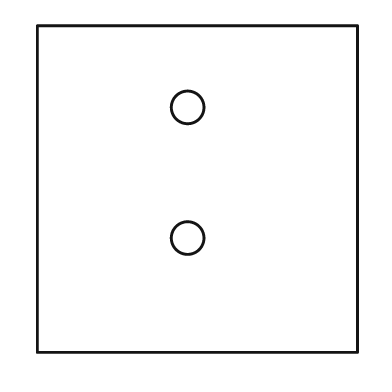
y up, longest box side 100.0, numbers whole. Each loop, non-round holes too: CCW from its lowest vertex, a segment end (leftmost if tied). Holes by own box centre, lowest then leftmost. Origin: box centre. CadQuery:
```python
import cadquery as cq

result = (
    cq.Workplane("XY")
    .moveTo(-49.0, -50.0)
    .lineTo(49.0, -50.0)
    .lineTo(49.0, 50.0)
    .lineTo(-49.0, 50.0)
    .close()
    .moveTo(-3.0, -15.0)
    .circle(5.0)
    .moveTo(-3.0, 25.0)
    .circle(5.0)
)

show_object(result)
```